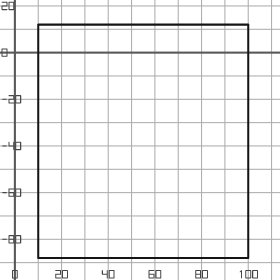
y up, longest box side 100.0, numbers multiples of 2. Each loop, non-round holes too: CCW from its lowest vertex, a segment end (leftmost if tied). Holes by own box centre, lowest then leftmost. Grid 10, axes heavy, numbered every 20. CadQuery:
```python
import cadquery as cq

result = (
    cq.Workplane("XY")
    .moveTo(10.0, -88.0)
    .lineTo(100.0, -88.0)
    .lineTo(100.0, 12.0)
    .lineTo(10.0, 12.0)
    .close()
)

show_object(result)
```